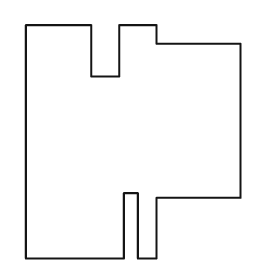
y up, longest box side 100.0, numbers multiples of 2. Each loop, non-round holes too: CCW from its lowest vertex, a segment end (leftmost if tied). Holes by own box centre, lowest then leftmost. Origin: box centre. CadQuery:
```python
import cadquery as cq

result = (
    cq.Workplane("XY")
    .moveTo(-46.0, -50.0)
    .lineTo(-4.0, -50.0)
    .lineTo(-4.0, -22.0)
    .lineTo(2.0, -22.0)
    .lineTo(2.0, -50.0)
    .lineTo(10.0, -50.0)
    .lineTo(10.0, -24.0)
    .lineTo(46.0, -24.0)
    .lineTo(46.0, 42.0)
    .lineTo(10.0, 42.0)
    .lineTo(10.0, 50.0)
    .lineTo(-6.0, 50.0)
    .lineTo(-6.0, 28.0)
    .lineTo(-18.0, 28.0)
    .lineTo(-18.0, 50.0)
    .lineTo(-46.0, 50.0)
    .close()
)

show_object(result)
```